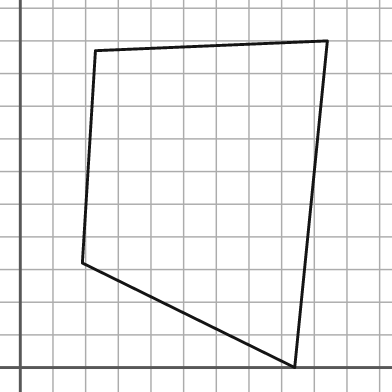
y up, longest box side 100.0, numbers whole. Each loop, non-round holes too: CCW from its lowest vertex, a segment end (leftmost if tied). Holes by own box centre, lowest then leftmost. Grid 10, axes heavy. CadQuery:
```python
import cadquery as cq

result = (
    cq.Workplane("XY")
    .moveTo(84.0, 0.0)
    .lineTo(94.0, 100.0)
    .lineTo(23.0, 97.0)
    .lineTo(19.0, 32.0)
    .close()
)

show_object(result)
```